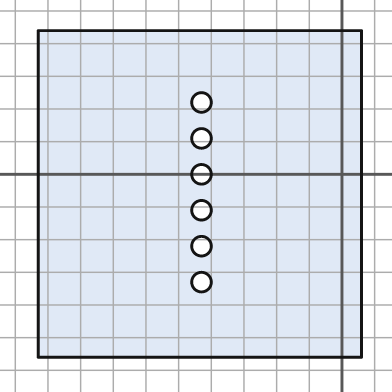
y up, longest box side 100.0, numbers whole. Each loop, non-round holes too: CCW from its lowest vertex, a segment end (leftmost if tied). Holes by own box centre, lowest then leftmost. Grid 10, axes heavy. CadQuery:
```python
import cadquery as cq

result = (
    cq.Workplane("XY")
    .moveTo(-93.0, -56.0)
    .lineTo(6.0, -56.0)
    .lineTo(6.0, 44.0)
    .lineTo(-93.0, 44.0)
    .close()
    .moveTo(-43.0, -33.0)
    .circle(3.0)
    .moveTo(-43.0, -22.0)
    .circle(3.0)
    .moveTo(-43.0, -11.0)
    .circle(3.0)
    .moveTo(-43.0, 0.0)
    .circle(3.0)
    .moveTo(-43.0, 11.0)
    .circle(3.0)
    .moveTo(-43.0, 22.0)
    .circle(3.0)
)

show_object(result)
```